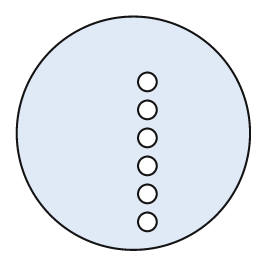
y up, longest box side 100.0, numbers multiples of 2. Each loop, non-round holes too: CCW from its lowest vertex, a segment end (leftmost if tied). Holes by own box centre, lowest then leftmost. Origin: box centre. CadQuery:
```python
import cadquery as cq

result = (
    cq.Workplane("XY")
    .moveTo(0.0, 0.0)
    .circle(50.0)
    .moveTo(6.0, -38.0)
    .circle(4.0)
    .moveTo(6.0, -26.0)
    .circle(4.0)
    .moveTo(6.0, -14.0)
    .circle(4.0)
    .moveTo(6.0, -2.0)
    .circle(4.0)
    .moveTo(6.0, 10.0)
    .circle(4.0)
    .moveTo(6.0, 22.0)
    .circle(4.0)
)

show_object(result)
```